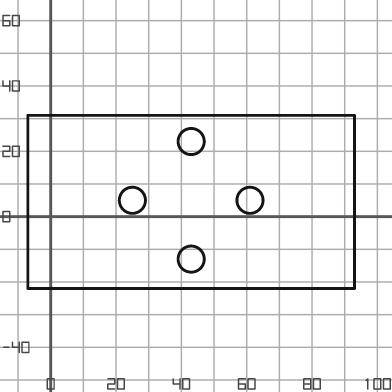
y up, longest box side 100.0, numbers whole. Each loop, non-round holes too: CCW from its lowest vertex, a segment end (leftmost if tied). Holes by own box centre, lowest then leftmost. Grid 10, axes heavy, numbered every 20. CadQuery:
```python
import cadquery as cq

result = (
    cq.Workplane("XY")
    .moveTo(-7.0, -22.0)
    .lineTo(93.0, -22.0)
    .lineTo(93.0, 31.0)
    .lineTo(-7.0, 31.0)
    .close()
    .moveTo(43.0, -13.0)
    .circle(4.0)
    .moveTo(25.0, 5.0)
    .circle(4.0)
    .moveTo(61.0, 5.0)
    .circle(4.0)
    .moveTo(43.0, 23.0)
    .circle(4.0)
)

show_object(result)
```